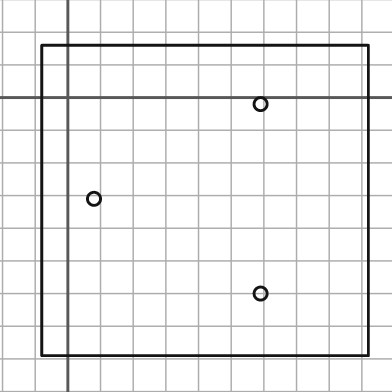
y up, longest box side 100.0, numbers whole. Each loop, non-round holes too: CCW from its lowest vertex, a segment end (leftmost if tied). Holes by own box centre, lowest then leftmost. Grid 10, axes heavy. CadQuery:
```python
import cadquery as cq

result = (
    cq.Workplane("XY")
    .moveTo(-8.0, -79.0)
    .lineTo(92.0, -79.0)
    .lineTo(92.0, 16.0)
    .lineTo(-8.0, 16.0)
    .close()
    .moveTo(59.0, -60.0)
    .circle(2.0)
    .moveTo(8.0, -31.0)
    .circle(2.0)
    .moveTo(59.0, -2.0)
    .circle(2.0)
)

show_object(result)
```